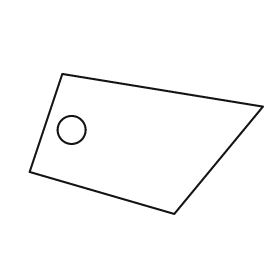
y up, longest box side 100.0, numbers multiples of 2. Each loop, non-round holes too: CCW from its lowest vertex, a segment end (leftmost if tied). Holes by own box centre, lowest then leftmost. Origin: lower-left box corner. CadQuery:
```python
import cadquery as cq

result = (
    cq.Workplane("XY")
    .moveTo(62.0, 0.0)
    .lineTo(100.0, 46.0)
    .lineTo(14.0, 60.0)
    .lineTo(0.0, 18.0)
    .close()
    .moveTo(18.0, 36.0)
    .circle(6.0)
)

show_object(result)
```